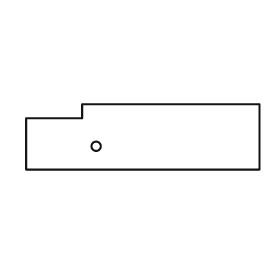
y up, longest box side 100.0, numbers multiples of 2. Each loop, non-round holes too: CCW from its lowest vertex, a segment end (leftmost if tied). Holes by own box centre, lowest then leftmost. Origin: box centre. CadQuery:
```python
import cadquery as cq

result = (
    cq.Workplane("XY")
    .moveTo(-50.0, -14.0)
    .lineTo(50.0, -14.0)
    .lineTo(50.0, 14.0)
    .lineTo(-26.0, 14.0)
    .lineTo(-26.0, 8.0)
    .lineTo(-50.0, 8.0)
    .close()
    .moveTo(-20.0, -4.0)
    .circle(2.0)
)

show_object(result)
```